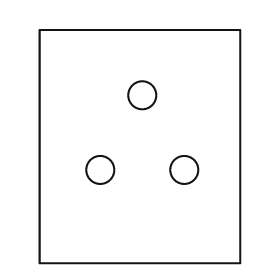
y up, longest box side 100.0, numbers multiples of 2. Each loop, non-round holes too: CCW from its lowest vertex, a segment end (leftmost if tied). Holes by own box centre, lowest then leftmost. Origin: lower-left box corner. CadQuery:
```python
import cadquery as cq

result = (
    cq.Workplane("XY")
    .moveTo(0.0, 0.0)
    .lineTo(86.0, 0.0)
    .lineTo(86.0, 100.0)
    .lineTo(0.0, 100.0)
    .close()
    .moveTo(26.0, 40.0)
    .circle(6.0)
    .moveTo(62.0, 40.0)
    .circle(6.0)
    .moveTo(44.0, 72.0)
    .circle(6.0)
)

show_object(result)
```